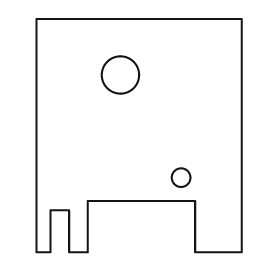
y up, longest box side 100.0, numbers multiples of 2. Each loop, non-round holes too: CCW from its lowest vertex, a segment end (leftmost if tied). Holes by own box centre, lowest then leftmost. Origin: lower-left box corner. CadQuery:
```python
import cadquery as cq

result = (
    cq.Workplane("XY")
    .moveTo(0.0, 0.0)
    .lineTo(6.0, 0.0)
    .lineTo(6.0, 18.0)
    .lineTo(14.0, 18.0)
    .lineTo(14.0, 0.0)
    .lineTo(22.0, 0.0)
    .lineTo(22.0, 22.0)
    .lineTo(68.0, 22.0)
    .lineTo(68.0, 0.0)
    .lineTo(88.0, 0.0)
    .lineTo(88.0, 100.0)
    .lineTo(0.0, 100.0)
    .close()
    .moveTo(62.0, 32.0)
    .circle(4.0)
    .moveTo(36.0, 76.0)
    .circle(8.0)
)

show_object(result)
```